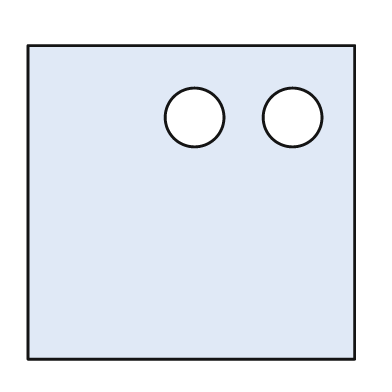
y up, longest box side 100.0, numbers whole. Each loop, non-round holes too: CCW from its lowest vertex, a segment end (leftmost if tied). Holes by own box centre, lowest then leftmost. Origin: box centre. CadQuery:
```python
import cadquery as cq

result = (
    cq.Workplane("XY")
    .moveTo(-50.0, -48.0)
    .lineTo(50.0, -48.0)
    .lineTo(50.0, 48.0)
    .lineTo(-50.0, 48.0)
    .close()
    .moveTo(1.0, 26.0)
    .circle(9.0)
    .moveTo(31.0, 26.0)
    .circle(9.0)
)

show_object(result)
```